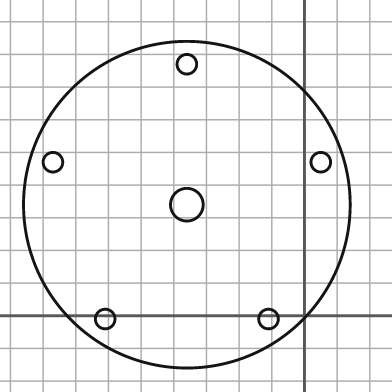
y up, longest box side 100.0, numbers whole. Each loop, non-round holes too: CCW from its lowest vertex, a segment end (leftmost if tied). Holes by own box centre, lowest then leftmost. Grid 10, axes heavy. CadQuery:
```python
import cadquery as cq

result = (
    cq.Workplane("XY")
    .moveTo(-36.0, 34.0)
    .circle(50.0)
    .moveTo(-61.0, -1.0)
    .circle(3.0)
    .moveTo(-11.0, -1.0)
    .circle(3.0)
    .moveTo(-36.0, 34.0)
    .circle(5.0)
    .moveTo(-77.0, 47.0)
    .circle(3.0)
    .moveTo(5.0, 47.0)
    .circle(3.0)
    .moveTo(-36.0, 77.0)
    .circle(3.0)
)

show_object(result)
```